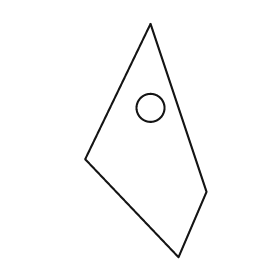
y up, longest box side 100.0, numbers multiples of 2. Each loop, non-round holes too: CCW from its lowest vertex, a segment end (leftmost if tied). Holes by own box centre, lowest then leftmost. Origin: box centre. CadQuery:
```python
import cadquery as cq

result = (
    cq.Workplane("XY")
    .moveTo(14.0, -50.0)
    .lineTo(26.0, -22.0)
    .lineTo(2.0, 50.0)
    .lineTo(-26.0, -8.0)
    .close()
    .moveTo(2.0, 14.0)
    .circle(6.0)
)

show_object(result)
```